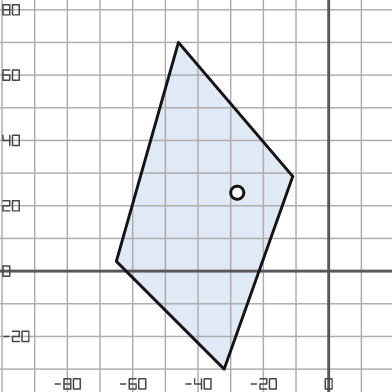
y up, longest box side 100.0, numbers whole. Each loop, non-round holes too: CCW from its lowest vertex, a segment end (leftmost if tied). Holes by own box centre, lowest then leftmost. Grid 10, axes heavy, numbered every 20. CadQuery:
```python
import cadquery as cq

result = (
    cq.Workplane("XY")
    .moveTo(-32.0, -30.0)
    .lineTo(-11.0, 29.0)
    .lineTo(-46.0, 70.0)
    .lineTo(-65.0, 3.0)
    .close()
    .moveTo(-28.0, 24.0)
    .circle(2.0)
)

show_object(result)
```